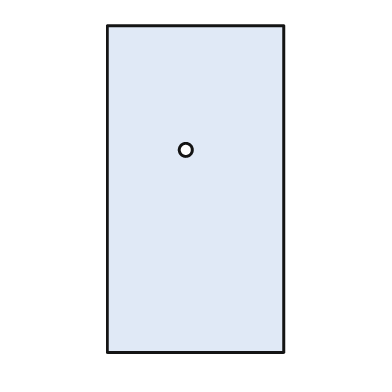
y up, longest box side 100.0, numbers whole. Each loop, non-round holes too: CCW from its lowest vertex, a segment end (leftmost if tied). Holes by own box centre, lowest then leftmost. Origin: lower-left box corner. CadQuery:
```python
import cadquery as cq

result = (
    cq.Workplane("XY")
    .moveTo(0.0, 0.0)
    .lineTo(54.0, 0.0)
    .lineTo(54.0, 100.0)
    .lineTo(0.0, 100.0)
    .close()
    .moveTo(24.0, 62.0)
    .circle(2.0)
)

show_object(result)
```